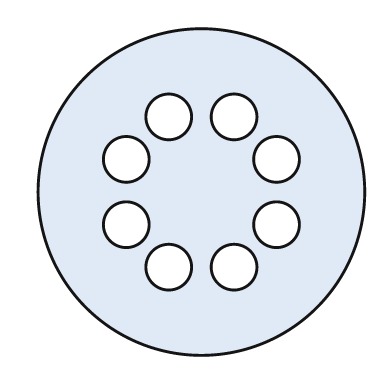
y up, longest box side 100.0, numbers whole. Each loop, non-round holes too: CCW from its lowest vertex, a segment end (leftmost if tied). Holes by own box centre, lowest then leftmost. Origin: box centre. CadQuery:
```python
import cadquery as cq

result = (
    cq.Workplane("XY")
    .moveTo(0.0, 0.0)
    .circle(50.0)
    .moveTo(-10.0, -23.0)
    .circle(7.0)
    .moveTo(10.0, -23.0)
    .circle(7.0)
    .moveTo(-23.0, -10.0)
    .circle(7.0)
    .moveTo(23.0, -10.0)
    .circle(7.0)
    .moveTo(-23.0, 10.0)
    .circle(7.0)
    .moveTo(23.0, 10.0)
    .circle(7.0)
    .moveTo(-10.0, 23.0)
    .circle(7.0)
    .moveTo(10.0, 23.0)
    .circle(7.0)
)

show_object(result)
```